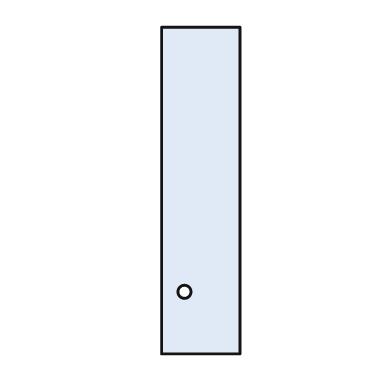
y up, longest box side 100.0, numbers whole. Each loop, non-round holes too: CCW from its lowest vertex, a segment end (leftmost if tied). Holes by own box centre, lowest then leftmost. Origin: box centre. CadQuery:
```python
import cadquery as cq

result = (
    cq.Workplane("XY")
    .moveTo(-12.0, -50.0)
    .lineTo(12.0, -50.0)
    .lineTo(12.0, 50.0)
    .lineTo(-12.0, 50.0)
    .close()
    .moveTo(-5.0, -31.0)
    .circle(2.0)
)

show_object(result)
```